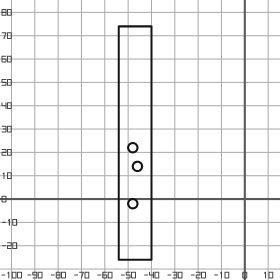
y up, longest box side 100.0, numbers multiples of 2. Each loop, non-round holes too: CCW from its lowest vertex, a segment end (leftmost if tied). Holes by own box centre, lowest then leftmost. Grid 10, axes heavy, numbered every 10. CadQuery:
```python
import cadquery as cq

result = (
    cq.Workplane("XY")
    .moveTo(-54.0, -26.0)
    .lineTo(-40.0, -26.0)
    .lineTo(-40.0, 74.0)
    .lineTo(-54.0, 74.0)
    .close()
    .moveTo(-48.0, -2.0)
    .circle(2.0)
    .moveTo(-46.0, 14.0)
    .circle(2.0)
    .moveTo(-48.0, 22.0)
    .circle(2.0)
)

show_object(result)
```